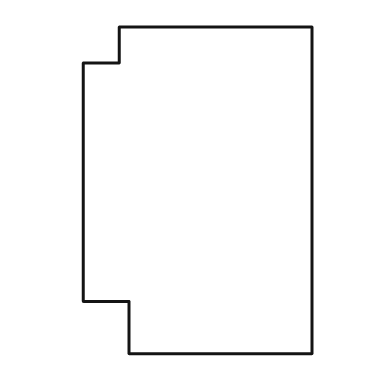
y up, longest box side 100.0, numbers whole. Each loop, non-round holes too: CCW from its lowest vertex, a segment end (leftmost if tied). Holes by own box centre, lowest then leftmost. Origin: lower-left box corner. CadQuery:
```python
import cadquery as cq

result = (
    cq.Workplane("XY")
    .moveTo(14.0, 0.0)
    .lineTo(70.0, 0.0)
    .lineTo(70.0, 100.0)
    .lineTo(11.0, 100.0)
    .lineTo(11.0, 89.0)
    .lineTo(0.0, 89.0)
    .lineTo(0.0, 16.0)
    .lineTo(14.0, 16.0)
    .close()
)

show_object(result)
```